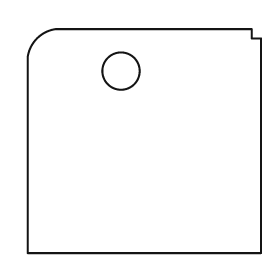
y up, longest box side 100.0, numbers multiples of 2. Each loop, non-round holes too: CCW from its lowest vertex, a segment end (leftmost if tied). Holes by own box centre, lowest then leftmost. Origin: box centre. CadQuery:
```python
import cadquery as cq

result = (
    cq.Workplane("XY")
    .moveTo(-50.0, -48.0)
    .lineTo(50.0, -48.0)
    .lineTo(50.0, 44.0)
    .lineTo(46.0, 44.0)
    .lineTo(46.0, 48.0)
    .lineTo(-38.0, 48.0)
    .threePointArc((-46.0, 44.0), (-50.0, 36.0))
    .close()
    .moveTo(-10.0, 30.0)
    .circle(8.0)
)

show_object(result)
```